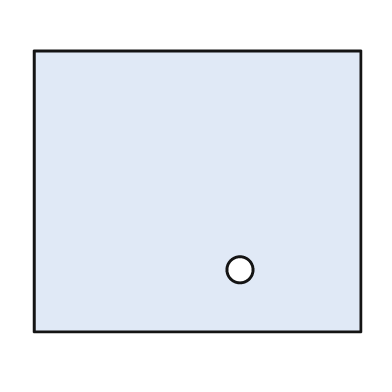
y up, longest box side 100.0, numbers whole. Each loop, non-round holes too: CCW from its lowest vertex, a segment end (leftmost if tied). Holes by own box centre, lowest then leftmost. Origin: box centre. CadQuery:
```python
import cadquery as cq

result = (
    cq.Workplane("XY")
    .moveTo(-50.0, -43.0)
    .lineTo(50.0, -43.0)
    .lineTo(50.0, 43.0)
    .lineTo(-50.0, 43.0)
    .close()
    .moveTo(13.0, -24.0)
    .circle(4.0)
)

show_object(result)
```